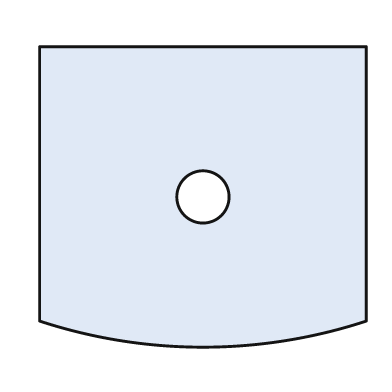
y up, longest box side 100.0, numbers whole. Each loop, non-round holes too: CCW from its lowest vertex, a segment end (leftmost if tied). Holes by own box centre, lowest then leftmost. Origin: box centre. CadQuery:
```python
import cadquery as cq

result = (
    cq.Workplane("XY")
    .moveTo(-50.0, -38.0)
    .threePointArc((0.0, -46.0), (50.0, -38.0))
    .lineTo(50.0, 46.0)
    .lineTo(-50.0, 46.0)
    .close()
    .moveTo(0.0, 0.0)
    .circle(8.0)
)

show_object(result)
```